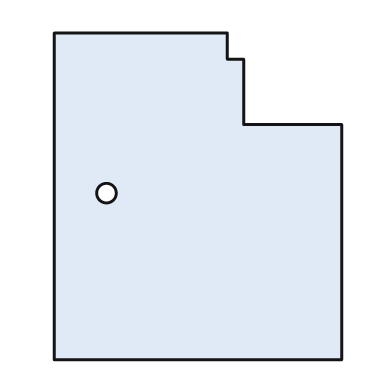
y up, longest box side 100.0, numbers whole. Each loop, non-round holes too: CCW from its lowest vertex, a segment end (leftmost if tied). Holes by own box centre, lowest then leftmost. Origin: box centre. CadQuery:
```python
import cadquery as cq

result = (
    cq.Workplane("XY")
    .moveTo(-44.0, -50.0)
    .lineTo(44.0, -50.0)
    .lineTo(44.0, 22.0)
    .lineTo(14.0, 22.0)
    .lineTo(14.0, 42.0)
    .lineTo(9.0, 42.0)
    .lineTo(9.0, 50.0)
    .lineTo(-44.0, 50.0)
    .close()
    .moveTo(-28.0, 1.0)
    .circle(3.0)
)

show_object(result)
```